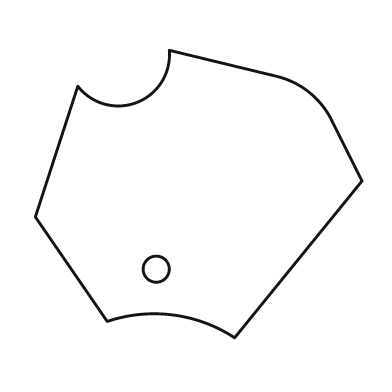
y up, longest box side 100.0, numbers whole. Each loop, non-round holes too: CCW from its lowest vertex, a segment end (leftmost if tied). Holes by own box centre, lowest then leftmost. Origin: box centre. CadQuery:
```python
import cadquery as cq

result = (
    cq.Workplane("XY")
    .moveTo(11.0, -44.0)
    .lineTo(50.0, 4.0)
    .lineTo(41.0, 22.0)
    .threePointArc((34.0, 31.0), (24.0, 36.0))
    .lineTo(-9.0, 44.0)
    .threePointArc((-19.0, 28.0), (-37.0, 33.0))
    .lineTo(-50.0, -7.0)
    .lineTo(-28.0, -39.0)
    .threePointArc((-8.0, -37.0), (11.0, -44.0))
    .close()
    .moveTo(-13.0, -23.0)
    .circle(4.0)
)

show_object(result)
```